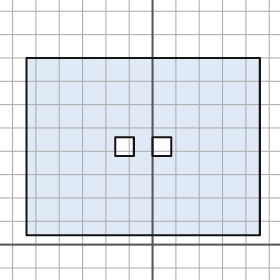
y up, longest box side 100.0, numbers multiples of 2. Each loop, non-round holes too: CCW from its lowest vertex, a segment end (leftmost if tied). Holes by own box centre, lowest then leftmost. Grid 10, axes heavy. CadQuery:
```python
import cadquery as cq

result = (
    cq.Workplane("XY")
    .moveTo(-54.0, 4.0)
    .lineTo(46.0, 4.0)
    .lineTo(46.0, 80.0)
    .lineTo(-54.0, 80.0)
    .close()
    .moveTo(-16.0, 38.0)
    .lineTo(-8.0, 38.0)
    .lineTo(-8.0, 46.0)
    .lineTo(-16.0, 46.0)
    .close()
    .moveTo(0.0, 38.0)
    .lineTo(8.0, 38.0)
    .lineTo(8.0, 46.0)
    .lineTo(0.0, 46.0)
    .close()
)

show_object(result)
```